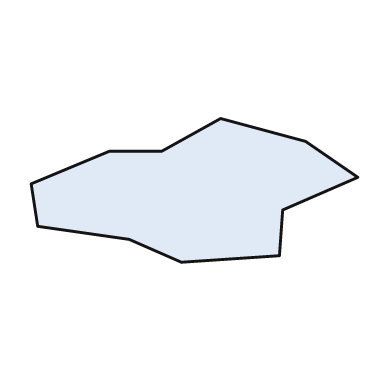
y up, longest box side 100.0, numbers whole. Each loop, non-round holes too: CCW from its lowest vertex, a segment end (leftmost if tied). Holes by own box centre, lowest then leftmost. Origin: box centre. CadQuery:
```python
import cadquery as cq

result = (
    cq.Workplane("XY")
    .moveTo(-4.0, -22.0)
    .lineTo(26.0, -20.0)
    .lineTo(27.0, -6.0)
    .lineTo(50.0, 4.0)
    .lineTo(34.0, 15.0)
    .lineTo(8.0, 22.0)
    .lineTo(-10.0, 12.0)
    .lineTo(-26.0, 12.0)
    .lineTo(-50.0, 2.0)
    .lineTo(-48.0, -11.0)
    .lineTo(-20.0, -15.0)
    .close()
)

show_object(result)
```